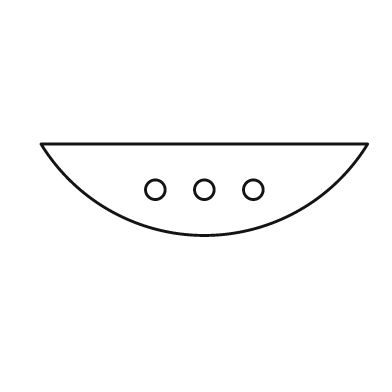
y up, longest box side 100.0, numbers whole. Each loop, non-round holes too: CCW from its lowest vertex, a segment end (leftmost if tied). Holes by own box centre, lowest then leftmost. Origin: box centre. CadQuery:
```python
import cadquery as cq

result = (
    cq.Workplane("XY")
    .moveTo(-50.0, 14.0)
    .threePointArc((0.0, -14.0), (50.0, 14.0))
    .close()
    .moveTo(-15.0, 0.0)
    .circle(3.0)
    .moveTo(0.0, 0.0)
    .circle(3.0)
    .moveTo(15.0, 0.0)
    .circle(3.0)
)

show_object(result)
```